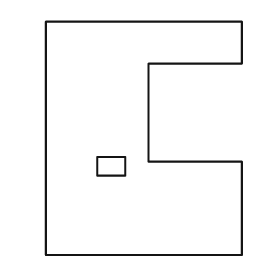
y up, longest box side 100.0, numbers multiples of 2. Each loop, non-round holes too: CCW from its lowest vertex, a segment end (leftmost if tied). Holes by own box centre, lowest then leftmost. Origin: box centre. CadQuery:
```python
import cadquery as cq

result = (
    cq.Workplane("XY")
    .moveTo(-42.0, -50.0)
    .lineTo(42.0, -50.0)
    .lineTo(42.0, -10.0)
    .lineTo(2.0, -10.0)
    .lineTo(2.0, 32.0)
    .lineTo(42.0, 32.0)
    .lineTo(42.0, 50.0)
    .lineTo(-42.0, 50.0)
    .close()
    .moveTo(-20.0, -16.0)
    .lineTo(-8.0, -16.0)
    .lineTo(-8.0, -8.0)
    .lineTo(-20.0, -8.0)
    .close()
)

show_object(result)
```